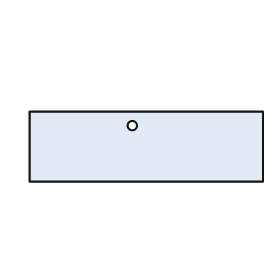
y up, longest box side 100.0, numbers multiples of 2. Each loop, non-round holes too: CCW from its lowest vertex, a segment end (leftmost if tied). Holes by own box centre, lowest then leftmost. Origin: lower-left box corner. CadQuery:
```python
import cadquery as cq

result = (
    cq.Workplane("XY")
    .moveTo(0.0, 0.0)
    .lineTo(100.0, 0.0)
    .lineTo(100.0, 30.0)
    .lineTo(0.0, 30.0)
    .close()
    .moveTo(44.0, 24.0)
    .circle(2.0)
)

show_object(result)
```